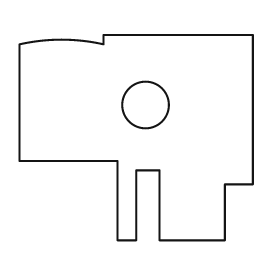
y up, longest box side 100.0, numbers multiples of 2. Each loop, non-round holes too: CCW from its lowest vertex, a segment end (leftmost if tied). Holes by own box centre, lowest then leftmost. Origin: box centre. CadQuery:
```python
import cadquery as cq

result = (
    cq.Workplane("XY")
    .moveTo(-8.0, -44.0)
    .lineTo(0.0, -44.0)
    .lineTo(0.0, -14.0)
    .lineTo(10.0, -14.0)
    .lineTo(10.0, -44.0)
    .lineTo(38.0, -44.0)
    .lineTo(38.0, -20.0)
    .lineTo(50.0, -20.0)
    .lineTo(50.0, 44.0)
    .lineTo(-14.0, 44.0)
    .lineTo(-14.0, 40.0)
    .threePointArc((-32.0, 42.0), (-50.0, 40.0))
    .lineTo(-50.0, -10.0)
    .lineTo(-8.0, -10.0)
    .close()
    .moveTo(4.0, 14.0)
    .circle(10.0)
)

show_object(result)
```